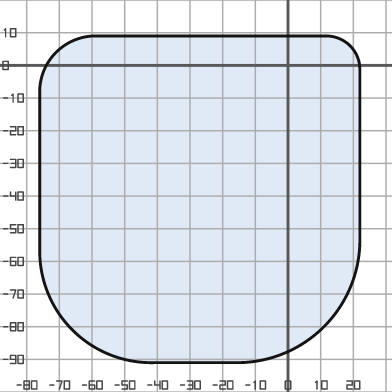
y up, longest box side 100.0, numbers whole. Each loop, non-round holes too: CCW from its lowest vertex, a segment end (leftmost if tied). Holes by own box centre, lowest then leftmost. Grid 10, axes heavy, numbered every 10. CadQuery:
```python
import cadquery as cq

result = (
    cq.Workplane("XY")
    .moveTo(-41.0, -91.0)
    .lineTo(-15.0, -91.0)
    .threePointArc((11.0, -80.0), (22.0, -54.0))
    .lineTo(22.0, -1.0)
    .threePointArc((19.0, 6.0), (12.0, 9.0))
    .lineTo(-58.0, 9.0)
    .threePointArc((-71.0, 4.0), (-76.0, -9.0))
    .lineTo(-76.0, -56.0)
    .threePointArc((-66.0, -81.0), (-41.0, -91.0))
    .close()
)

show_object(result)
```